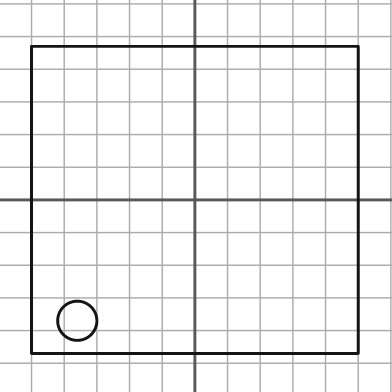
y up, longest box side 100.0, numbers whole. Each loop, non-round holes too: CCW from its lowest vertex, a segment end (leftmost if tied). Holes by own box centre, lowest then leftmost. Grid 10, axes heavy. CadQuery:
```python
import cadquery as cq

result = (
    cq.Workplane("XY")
    .moveTo(-50.0, -47.0)
    .lineTo(50.0, -47.0)
    .lineTo(50.0, 47.0)
    .lineTo(-50.0, 47.0)
    .close()
    .moveTo(-36.0, -37.0)
    .circle(6.0)
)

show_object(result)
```